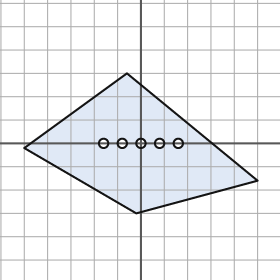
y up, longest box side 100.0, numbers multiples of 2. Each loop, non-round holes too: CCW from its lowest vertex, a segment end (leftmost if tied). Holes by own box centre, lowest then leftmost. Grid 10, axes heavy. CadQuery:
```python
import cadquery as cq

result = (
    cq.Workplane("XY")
    .moveTo(-2.0, -30.0)
    .lineTo(50.0, -16.0)
    .lineTo(-6.0, 30.0)
    .lineTo(-50.0, -2.0)
    .close()
    .moveTo(-16.0, 0.0)
    .circle(2.0)
    .moveTo(-8.0, 0.0)
    .circle(2.0)
    .moveTo(0.0, 0.0)
    .circle(2.0)
    .moveTo(8.0, 0.0)
    .circle(2.0)
    .moveTo(16.0, 0.0)
    .circle(2.0)
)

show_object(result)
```